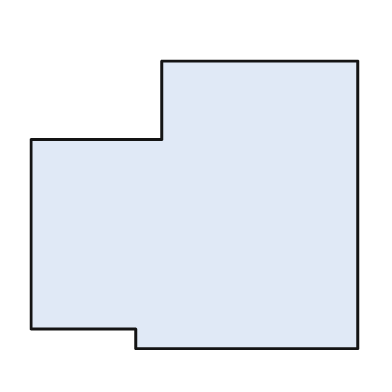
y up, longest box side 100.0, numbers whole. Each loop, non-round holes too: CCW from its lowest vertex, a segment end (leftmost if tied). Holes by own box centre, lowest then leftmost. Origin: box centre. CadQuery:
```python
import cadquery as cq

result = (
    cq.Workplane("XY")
    .moveTo(-18.0, -44.0)
    .lineTo(50.0, -44.0)
    .lineTo(50.0, 44.0)
    .lineTo(-10.0, 44.0)
    .lineTo(-10.0, 20.0)
    .lineTo(-50.0, 20.0)
    .lineTo(-50.0, -38.0)
    .lineTo(-18.0, -38.0)
    .close()
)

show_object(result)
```